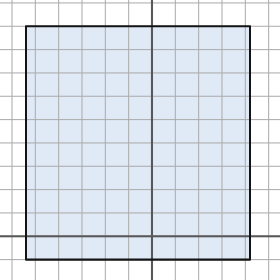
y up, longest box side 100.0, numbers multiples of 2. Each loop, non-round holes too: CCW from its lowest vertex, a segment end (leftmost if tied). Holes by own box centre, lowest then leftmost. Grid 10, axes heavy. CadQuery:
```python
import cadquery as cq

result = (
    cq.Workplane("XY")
    .moveTo(-54.0, -10.0)
    .lineTo(42.0, -10.0)
    .lineTo(42.0, 90.0)
    .lineTo(-54.0, 90.0)
    .close()
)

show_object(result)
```